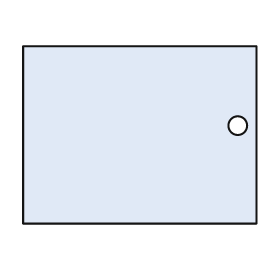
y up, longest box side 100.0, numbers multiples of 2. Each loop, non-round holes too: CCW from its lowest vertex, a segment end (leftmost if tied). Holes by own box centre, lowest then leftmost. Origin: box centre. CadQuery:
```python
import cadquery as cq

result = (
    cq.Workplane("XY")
    .moveTo(-50.0, -38.0)
    .lineTo(50.0, -38.0)
    .lineTo(50.0, 38.0)
    .lineTo(-50.0, 38.0)
    .close()
    .moveTo(42.0, 4.0)
    .circle(4.0)
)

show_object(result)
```